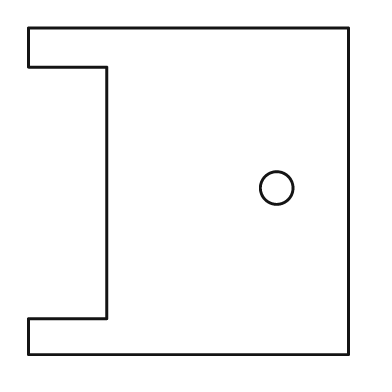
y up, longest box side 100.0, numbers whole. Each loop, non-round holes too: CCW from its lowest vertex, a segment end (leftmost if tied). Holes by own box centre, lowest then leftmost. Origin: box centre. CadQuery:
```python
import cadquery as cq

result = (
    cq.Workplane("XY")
    .moveTo(-49.0, -50.0)
    .lineTo(49.0, -50.0)
    .lineTo(49.0, 50.0)
    .lineTo(-49.0, 50.0)
    .lineTo(-49.0, 38.0)
    .lineTo(-25.0, 38.0)
    .lineTo(-25.0, -39.0)
    .lineTo(-49.0, -39.0)
    .close()
    .moveTo(27.0, 1.0)
    .circle(5.0)
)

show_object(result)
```